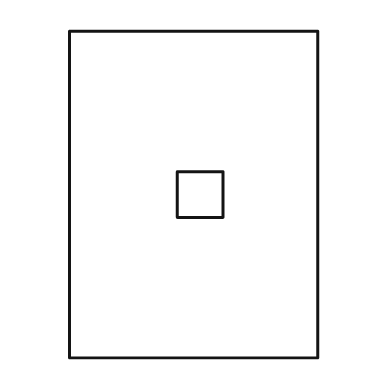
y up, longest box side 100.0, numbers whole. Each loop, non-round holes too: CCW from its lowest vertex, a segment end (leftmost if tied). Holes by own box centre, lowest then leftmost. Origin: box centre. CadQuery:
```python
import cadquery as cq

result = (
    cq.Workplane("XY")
    .moveTo(-38.0, -50.0)
    .lineTo(38.0, -50.0)
    .lineTo(38.0, 50.0)
    .lineTo(-38.0, 50.0)
    .close()
    .moveTo(-5.0, -7.0)
    .lineTo(9.0, -7.0)
    .lineTo(9.0, 7.0)
    .lineTo(-5.0, 7.0)
    .close()
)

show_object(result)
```